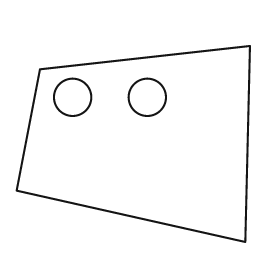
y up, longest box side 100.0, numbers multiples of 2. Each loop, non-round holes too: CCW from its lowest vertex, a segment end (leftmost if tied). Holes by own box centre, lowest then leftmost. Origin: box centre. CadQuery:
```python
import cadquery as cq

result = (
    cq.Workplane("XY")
    .moveTo(48.0, -42.0)
    .lineTo(50.0, 42.0)
    .lineTo(-40.0, 32.0)
    .lineTo(-50.0, -20.0)
    .close()
    .moveTo(-26.0, 20.0)
    .circle(8.0)
    .moveTo(6.0, 20.0)
    .circle(8.0)
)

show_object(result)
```